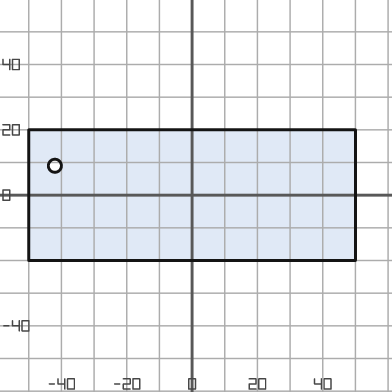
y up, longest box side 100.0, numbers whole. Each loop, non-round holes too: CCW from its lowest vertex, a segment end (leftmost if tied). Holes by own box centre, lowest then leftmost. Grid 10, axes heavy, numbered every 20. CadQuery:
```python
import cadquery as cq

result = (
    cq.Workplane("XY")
    .moveTo(-50.0, -20.0)
    .lineTo(50.0, -20.0)
    .lineTo(50.0, 20.0)
    .lineTo(-50.0, 20.0)
    .close()
    .moveTo(-42.0, 9.0)
    .circle(2.0)
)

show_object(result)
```